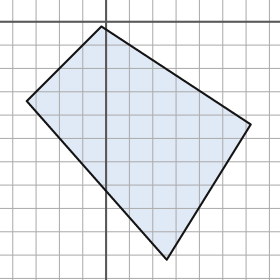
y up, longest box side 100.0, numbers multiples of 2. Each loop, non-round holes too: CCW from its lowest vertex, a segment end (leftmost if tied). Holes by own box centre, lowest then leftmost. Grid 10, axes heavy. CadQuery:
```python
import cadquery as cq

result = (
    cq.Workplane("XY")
    .moveTo(26.0, -102.0)
    .lineTo(62.0, -44.0)
    .lineTo(-2.0, -2.0)
    .lineTo(-34.0, -34.0)
    .close()
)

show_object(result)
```